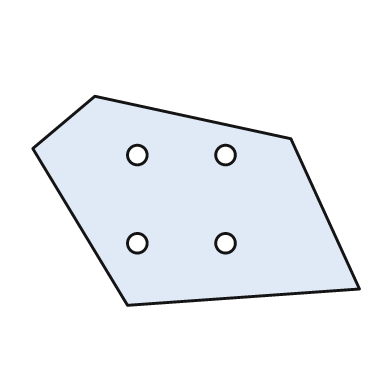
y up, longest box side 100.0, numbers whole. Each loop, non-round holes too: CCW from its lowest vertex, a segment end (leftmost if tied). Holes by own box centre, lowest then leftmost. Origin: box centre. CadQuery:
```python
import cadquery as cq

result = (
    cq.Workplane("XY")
    .moveTo(-21.0, -32.0)
    .lineTo(50.0, -27.0)
    .lineTo(29.0, 19.0)
    .lineTo(-31.0, 32.0)
    .lineTo(-50.0, 16.0)
    .close()
    .moveTo(-18.0, -13.0)
    .circle(3.0)
    .moveTo(9.0, -13.0)
    .circle(3.0)
    .moveTo(-18.0, 14.0)
    .circle(3.0)
    .moveTo(9.0, 14.0)
    .circle(3.0)
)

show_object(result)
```